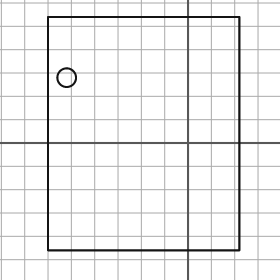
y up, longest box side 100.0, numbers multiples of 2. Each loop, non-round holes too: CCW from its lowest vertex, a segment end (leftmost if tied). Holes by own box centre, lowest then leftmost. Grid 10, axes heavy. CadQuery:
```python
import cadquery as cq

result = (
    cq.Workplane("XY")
    .moveTo(-60.0, -46.0)
    .lineTo(22.0, -46.0)
    .lineTo(22.0, 54.0)
    .lineTo(-60.0, 54.0)
    .close()
    .moveTo(-52.0, 28.0)
    .circle(4.0)
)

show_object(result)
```